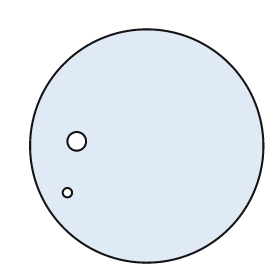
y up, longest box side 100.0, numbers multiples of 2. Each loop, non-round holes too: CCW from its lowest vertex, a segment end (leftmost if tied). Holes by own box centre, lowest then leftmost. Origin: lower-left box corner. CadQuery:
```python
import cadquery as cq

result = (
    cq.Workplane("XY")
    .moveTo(50.0, 50.0)
    .circle(50.0)
    .moveTo(16.0, 30.0)
    .circle(2.0)
    .moveTo(20.0, 52.0)
    .circle(4.0)
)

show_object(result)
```